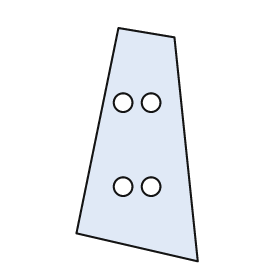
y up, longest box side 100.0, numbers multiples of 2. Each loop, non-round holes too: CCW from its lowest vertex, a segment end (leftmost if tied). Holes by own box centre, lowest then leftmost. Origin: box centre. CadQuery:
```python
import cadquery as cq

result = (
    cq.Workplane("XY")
    .moveTo(26.0, -50.0)
    .lineTo(16.0, 46.0)
    .lineTo(-8.0, 50.0)
    .lineTo(-26.0, -38.0)
    .close()
    .moveTo(-6.0, -18.0)
    .circle(4.0)
    .moveTo(6.0, -18.0)
    .circle(4.0)
    .moveTo(-6.0, 18.0)
    .circle(4.0)
    .moveTo(6.0, 18.0)
    .circle(4.0)
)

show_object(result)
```